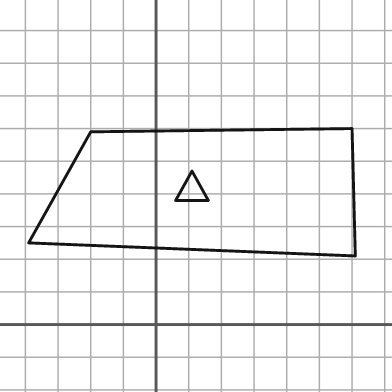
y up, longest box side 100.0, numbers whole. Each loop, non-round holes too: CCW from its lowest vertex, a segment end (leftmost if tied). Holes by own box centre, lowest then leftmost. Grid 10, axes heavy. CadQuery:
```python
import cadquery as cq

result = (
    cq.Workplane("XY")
    .moveTo(61.0, 21.0)
    .lineTo(60.0, 60.0)
    .lineTo(-20.0, 59.0)
    .lineTo(-39.0, 25.0)
    .close()
    .moveTo(6.0, 38.0)
    .lineTo(16.0, 38.0)
    .lineTo(11.0, 47.0)
    .close()
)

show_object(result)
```